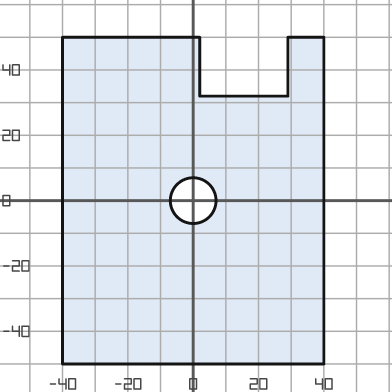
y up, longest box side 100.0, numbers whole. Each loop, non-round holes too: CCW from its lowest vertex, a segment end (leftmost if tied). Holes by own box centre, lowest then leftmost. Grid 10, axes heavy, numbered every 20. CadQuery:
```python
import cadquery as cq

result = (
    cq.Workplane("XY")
    .moveTo(-40.0, -50.0)
    .lineTo(40.0, -50.0)
    .lineTo(40.0, 50.0)
    .lineTo(29.0, 50.0)
    .lineTo(29.0, 32.0)
    .lineTo(2.0, 32.0)
    .lineTo(2.0, 50.0)
    .lineTo(-40.0, 50.0)
    .close()
    .moveTo(0.0, 0.0)
    .circle(7.0)
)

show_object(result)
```